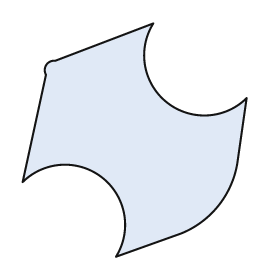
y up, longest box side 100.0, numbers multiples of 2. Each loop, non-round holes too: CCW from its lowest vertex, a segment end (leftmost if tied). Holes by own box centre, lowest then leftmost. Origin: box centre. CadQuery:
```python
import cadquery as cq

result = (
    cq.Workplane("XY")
    .moveTo(-8.0, -50.0)
    .lineTo(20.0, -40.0)
    .threePointArc((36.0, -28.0), (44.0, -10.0))
    .lineTo(48.0, 18.0)
    .threePointArc((14.0, 16.0), (8.0, 50.0))
    .lineTo(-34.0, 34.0)
    .threePointArc((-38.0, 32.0), (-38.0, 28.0))
    .lineTo(-48.0, -18.0)
    .threePointArc((-14.0, -16.0), (-8.0, -50.0))
    .close()
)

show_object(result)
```